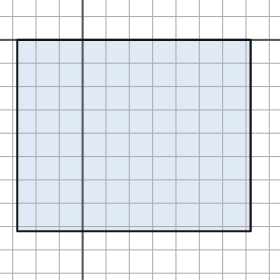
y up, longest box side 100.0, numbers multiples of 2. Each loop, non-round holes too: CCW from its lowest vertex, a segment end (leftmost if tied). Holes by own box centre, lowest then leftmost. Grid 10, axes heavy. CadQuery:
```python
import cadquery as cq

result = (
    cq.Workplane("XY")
    .moveTo(-28.0, -82.0)
    .lineTo(72.0, -82.0)
    .lineTo(72.0, 0.0)
    .lineTo(-28.0, 0.0)
    .close()
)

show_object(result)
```